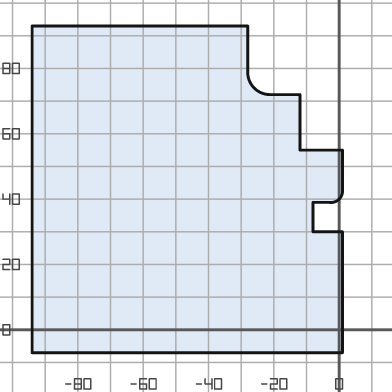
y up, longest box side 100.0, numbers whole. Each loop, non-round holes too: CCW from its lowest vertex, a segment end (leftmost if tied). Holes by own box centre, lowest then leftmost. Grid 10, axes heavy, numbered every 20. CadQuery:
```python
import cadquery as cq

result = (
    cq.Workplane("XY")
    .moveTo(-94.0, -7.0)
    .lineTo(1.0, -7.0)
    .lineTo(1.0, 30.0)
    .lineTo(-8.0, 30.0)
    .lineTo(-8.0, 39.0)
    .lineTo(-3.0, 39.0)
    .threePointArc((0.0, 40.0), (1.0, 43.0))
    .lineTo(1.0, 55.0)
    .lineTo(-12.0, 55.0)
    .lineTo(-12.0, 72.0)
    .lineTo(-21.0, 72.0)
    .threePointArc((-26.0, 74.0), (-28.0, 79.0))
    .lineTo(-28.0, 93.0)
    .lineTo(-94.0, 93.0)
    .close()
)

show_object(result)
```